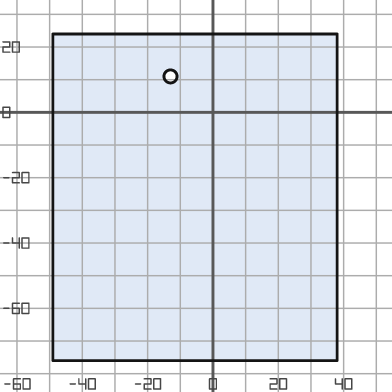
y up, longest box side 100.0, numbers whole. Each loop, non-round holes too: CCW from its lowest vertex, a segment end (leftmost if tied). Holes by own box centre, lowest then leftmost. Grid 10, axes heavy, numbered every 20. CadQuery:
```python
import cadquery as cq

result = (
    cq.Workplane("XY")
    .moveTo(-49.0, -76.0)
    .lineTo(38.0, -76.0)
    .lineTo(38.0, 24.0)
    .lineTo(-49.0, 24.0)
    .close()
    .moveTo(-13.0, 11.0)
    .circle(2.0)
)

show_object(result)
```